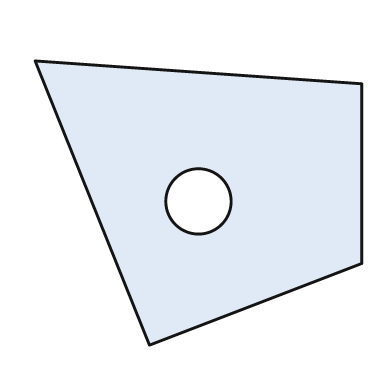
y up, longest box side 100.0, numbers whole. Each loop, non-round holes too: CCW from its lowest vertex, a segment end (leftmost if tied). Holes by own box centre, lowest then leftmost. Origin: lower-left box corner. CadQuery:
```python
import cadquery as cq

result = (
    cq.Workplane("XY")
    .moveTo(35.0, 0.0)
    .lineTo(100.0, 25.0)
    .lineTo(100.0, 80.0)
    .lineTo(0.0, 87.0)
    .close()
    .moveTo(50.0, 44.0)
    .circle(10.0)
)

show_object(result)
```